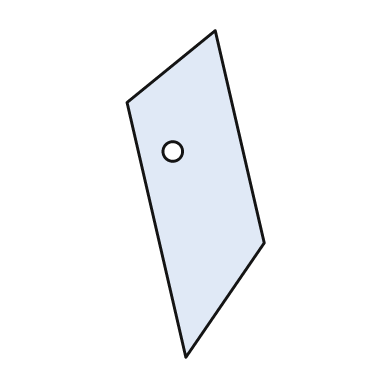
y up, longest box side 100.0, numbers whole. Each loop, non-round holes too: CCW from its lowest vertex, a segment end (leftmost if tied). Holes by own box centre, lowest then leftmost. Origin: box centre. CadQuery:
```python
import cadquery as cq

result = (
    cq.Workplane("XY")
    .moveTo(-3.0, -50.0)
    .lineTo(21.0, -15.0)
    .lineTo(6.0, 50.0)
    .lineTo(-21.0, 28.0)
    .close()
    .moveTo(-7.0, 13.0)
    .circle(3.0)
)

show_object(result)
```